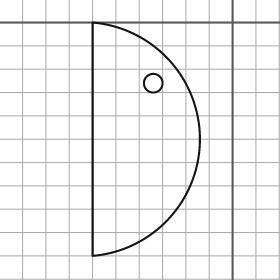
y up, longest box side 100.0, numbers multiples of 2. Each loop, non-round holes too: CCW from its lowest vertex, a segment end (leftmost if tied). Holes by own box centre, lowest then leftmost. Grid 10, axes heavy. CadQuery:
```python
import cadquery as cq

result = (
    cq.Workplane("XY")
    .moveTo(-60.0, -100.0)
    .threePointArc((-14.0, -50.0), (-60.0, 0.0))
    .close()
    .moveTo(-34.0, -26.0)
    .circle(4.0)
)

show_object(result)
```